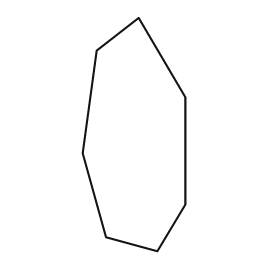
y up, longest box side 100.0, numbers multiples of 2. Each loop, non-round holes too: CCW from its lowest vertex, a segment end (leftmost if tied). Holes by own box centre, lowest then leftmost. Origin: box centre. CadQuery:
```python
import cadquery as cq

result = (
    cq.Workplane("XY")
    .moveTo(10.0, -50.0)
    .lineTo(22.0, -30.0)
    .lineTo(22.0, 16.0)
    .lineTo(2.0, 50.0)
    .lineTo(-16.0, 36.0)
    .lineTo(-22.0, -8.0)
    .lineTo(-12.0, -44.0)
    .close()
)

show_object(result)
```